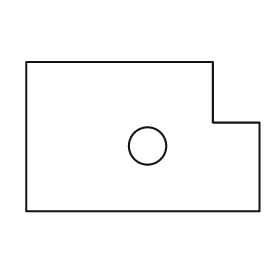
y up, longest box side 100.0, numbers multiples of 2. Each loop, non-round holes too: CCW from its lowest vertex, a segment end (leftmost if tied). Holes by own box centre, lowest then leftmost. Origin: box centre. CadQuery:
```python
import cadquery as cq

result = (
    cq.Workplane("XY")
    .moveTo(-50.0, -32.0)
    .lineTo(50.0, -32.0)
    .lineTo(50.0, 6.0)
    .lineTo(30.0, 6.0)
    .lineTo(30.0, 32.0)
    .lineTo(-50.0, 32.0)
    .close()
    .moveTo(2.0, -4.0)
    .circle(8.0)
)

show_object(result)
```